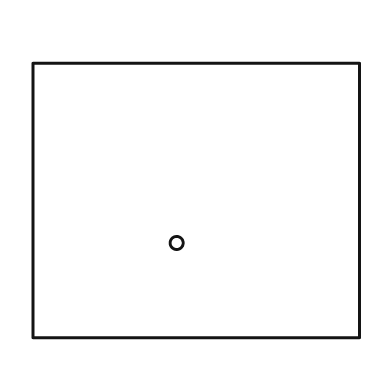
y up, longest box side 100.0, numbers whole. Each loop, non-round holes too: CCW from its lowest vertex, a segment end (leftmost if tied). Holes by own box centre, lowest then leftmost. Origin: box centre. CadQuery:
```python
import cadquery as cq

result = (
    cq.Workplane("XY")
    .moveTo(-50.0, -42.0)
    .lineTo(50.0, -42.0)
    .lineTo(50.0, 42.0)
    .lineTo(-50.0, 42.0)
    .close()
    .moveTo(-6.0, -13.0)
    .circle(2.0)
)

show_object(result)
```